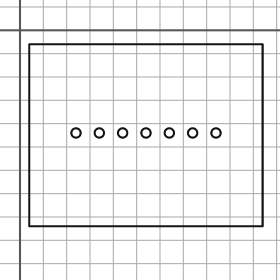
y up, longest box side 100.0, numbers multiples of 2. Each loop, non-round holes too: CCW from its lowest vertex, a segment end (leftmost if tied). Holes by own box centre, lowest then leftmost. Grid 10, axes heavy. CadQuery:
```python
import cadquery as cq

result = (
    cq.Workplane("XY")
    .moveTo(4.0, -84.0)
    .lineTo(104.0, -84.0)
    .lineTo(104.0, -6.0)
    .lineTo(4.0, -6.0)
    .close()
    .moveTo(24.0, -44.0)
    .circle(2.0)
    .moveTo(34.0, -44.0)
    .circle(2.0)
    .moveTo(44.0, -44.0)
    .circle(2.0)
    .moveTo(54.0, -44.0)
    .circle(2.0)
    .moveTo(64.0, -44.0)
    .circle(2.0)
    .moveTo(74.0, -44.0)
    .circle(2.0)
    .moveTo(84.0, -44.0)
    .circle(2.0)
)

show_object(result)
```